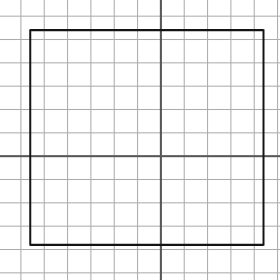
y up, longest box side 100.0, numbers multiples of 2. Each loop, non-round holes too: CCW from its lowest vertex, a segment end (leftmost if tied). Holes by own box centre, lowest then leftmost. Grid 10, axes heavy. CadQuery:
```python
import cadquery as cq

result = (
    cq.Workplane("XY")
    .moveTo(-56.0, -38.0)
    .lineTo(44.0, -38.0)
    .lineTo(44.0, 54.0)
    .lineTo(-56.0, 54.0)
    .close()
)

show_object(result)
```